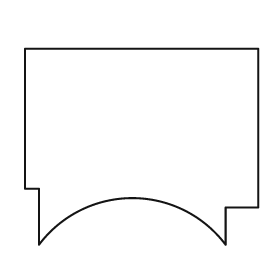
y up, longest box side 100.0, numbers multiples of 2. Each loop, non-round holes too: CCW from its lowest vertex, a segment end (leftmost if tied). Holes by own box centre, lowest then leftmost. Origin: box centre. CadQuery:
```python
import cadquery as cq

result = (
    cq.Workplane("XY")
    .moveTo(-44.0, -42.0)
    .threePointArc((-4.0, -22.0), (36.0, -42.0))
    .lineTo(36.0, -26.0)
    .lineTo(50.0, -26.0)
    .lineTo(50.0, 42.0)
    .lineTo(-50.0, 42.0)
    .lineTo(-50.0, -18.0)
    .lineTo(-44.0, -18.0)
    .close()
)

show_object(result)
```